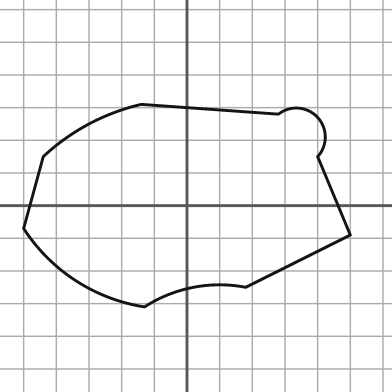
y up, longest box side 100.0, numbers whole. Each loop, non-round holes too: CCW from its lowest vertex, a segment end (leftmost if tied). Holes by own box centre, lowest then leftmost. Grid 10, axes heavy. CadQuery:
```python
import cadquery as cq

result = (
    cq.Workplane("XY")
    .moveTo(-13.0, -31.0)
    .threePointArc((2.0, -25.0), (18.0, -25.0))
    .lineTo(50.0, -9.0)
    .lineTo(40.0, 15.0)
    .threePointArc((40.0, 27.0), (28.0, 28.0))
    .lineTo(-14.0, 31.0)
    .threePointArc((-30.0, 25.0), (-44.0, 15.0))
    .lineTo(-50.0, -7.0)
    .threePointArc((-34.0, -23.0), (-13.0, -31.0))
    .close()
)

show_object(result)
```